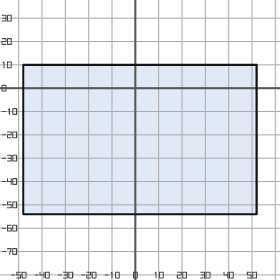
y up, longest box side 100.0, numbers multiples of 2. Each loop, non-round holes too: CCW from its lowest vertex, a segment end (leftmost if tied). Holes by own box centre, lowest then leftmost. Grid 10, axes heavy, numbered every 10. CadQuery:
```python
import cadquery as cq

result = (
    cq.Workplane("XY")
    .moveTo(-48.0, -54.0)
    .lineTo(52.0, -54.0)
    .lineTo(52.0, 10.0)
    .lineTo(-48.0, 10.0)
    .close()
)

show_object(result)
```